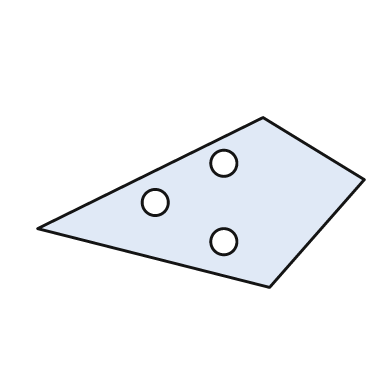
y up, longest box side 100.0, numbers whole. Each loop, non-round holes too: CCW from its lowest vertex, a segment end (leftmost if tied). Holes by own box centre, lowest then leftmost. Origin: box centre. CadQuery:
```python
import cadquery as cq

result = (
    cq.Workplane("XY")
    .moveTo(21.0, -26.0)
    .lineTo(50.0, 7.0)
    .lineTo(19.0, 26.0)
    .lineTo(-50.0, -8.0)
    .close()
    .moveTo(7.0, -12.0)
    .circle(4.0)
    .moveTo(-14.0, 0.0)
    .circle(4.0)
    .moveTo(7.0, 12.0)
    .circle(4.0)
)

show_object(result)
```